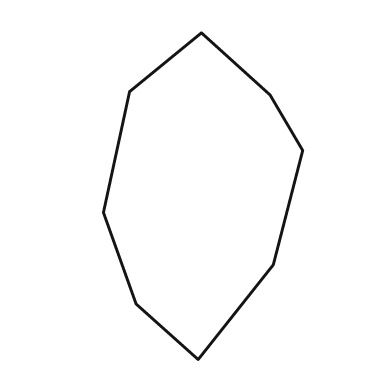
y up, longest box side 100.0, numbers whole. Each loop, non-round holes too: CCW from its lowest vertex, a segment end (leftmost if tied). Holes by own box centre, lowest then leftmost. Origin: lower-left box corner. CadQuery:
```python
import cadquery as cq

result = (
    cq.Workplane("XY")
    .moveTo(29.0, 0.0)
    .lineTo(52.0, 29.0)
    .lineTo(61.0, 64.0)
    .lineTo(51.0, 81.0)
    .lineTo(30.0, 100.0)
    .lineTo(8.0, 82.0)
    .lineTo(0.0, 45.0)
    .lineTo(10.0, 17.0)
    .close()
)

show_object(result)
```